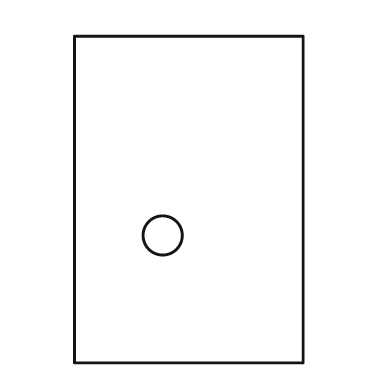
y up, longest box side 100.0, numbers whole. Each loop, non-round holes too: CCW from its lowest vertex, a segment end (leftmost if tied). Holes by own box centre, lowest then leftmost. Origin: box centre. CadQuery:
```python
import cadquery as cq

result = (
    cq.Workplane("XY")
    .moveTo(-35.0, -50.0)
    .lineTo(35.0, -50.0)
    .lineTo(35.0, 50.0)
    .lineTo(-35.0, 50.0)
    .close()
    .moveTo(-8.0, -11.0)
    .circle(6.0)
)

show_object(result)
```